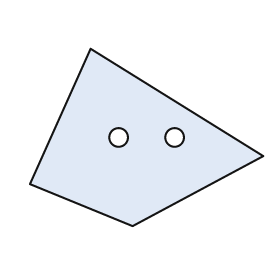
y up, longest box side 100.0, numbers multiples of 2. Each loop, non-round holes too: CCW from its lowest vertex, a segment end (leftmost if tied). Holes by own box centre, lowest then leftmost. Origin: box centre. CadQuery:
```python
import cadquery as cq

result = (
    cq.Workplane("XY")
    .moveTo(-6.0, -38.0)
    .lineTo(50.0, -8.0)
    .lineTo(-24.0, 38.0)
    .lineTo(-50.0, -20.0)
    .close()
    .moveTo(-12.0, 0.0)
    .circle(4.0)
    .moveTo(12.0, 0.0)
    .circle(4.0)
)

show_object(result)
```